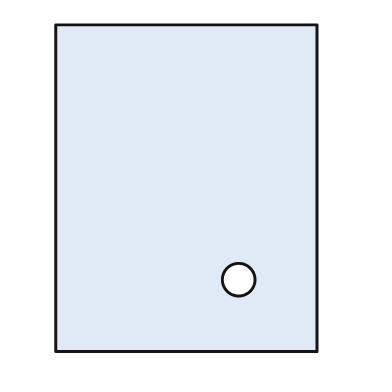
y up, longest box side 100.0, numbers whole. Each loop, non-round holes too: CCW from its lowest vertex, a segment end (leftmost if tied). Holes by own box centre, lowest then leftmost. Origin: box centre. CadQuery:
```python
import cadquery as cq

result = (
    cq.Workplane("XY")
    .moveTo(-40.0, -50.0)
    .lineTo(40.0, -50.0)
    .lineTo(40.0, 50.0)
    .lineTo(-40.0, 50.0)
    .close()
    .moveTo(16.0, -28.0)
    .circle(5.0)
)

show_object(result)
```